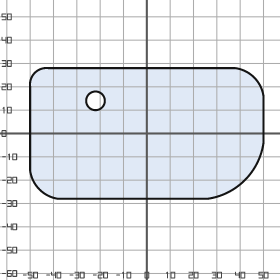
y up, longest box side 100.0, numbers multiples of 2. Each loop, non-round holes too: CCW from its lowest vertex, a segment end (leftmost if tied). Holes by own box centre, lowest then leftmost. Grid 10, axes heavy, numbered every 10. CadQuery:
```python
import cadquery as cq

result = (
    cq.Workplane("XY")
    .moveTo(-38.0, -28.0)
    .lineTo(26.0, -28.0)
    .threePointArc((42.0, -20.0), (50.0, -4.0))
    .lineTo(50.0, 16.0)
    .threePointArc((46.0, 24.0), (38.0, 28.0))
    .lineTo(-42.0, 28.0)
    .threePointArc((-48.0, 26.0), (-50.0, 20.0))
    .lineTo(-50.0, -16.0)
    .threePointArc((-46.0, -24.0), (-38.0, -28.0))
    .close()
    .moveTo(-22.0, 14.0)
    .circle(4.0)
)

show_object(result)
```